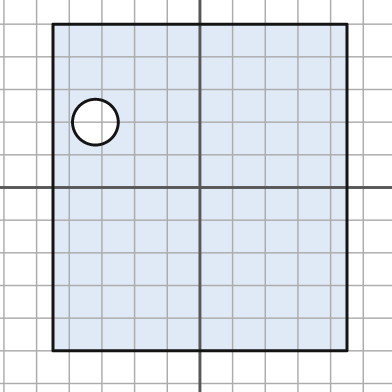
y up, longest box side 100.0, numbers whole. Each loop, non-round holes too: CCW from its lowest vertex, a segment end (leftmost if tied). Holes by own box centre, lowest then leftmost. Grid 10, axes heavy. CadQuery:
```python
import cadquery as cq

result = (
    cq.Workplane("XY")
    .moveTo(-45.0, -50.0)
    .lineTo(45.0, -50.0)
    .lineTo(45.0, 50.0)
    .lineTo(-45.0, 50.0)
    .close()
    .moveTo(-32.0, 20.0)
    .circle(7.0)
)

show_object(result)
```